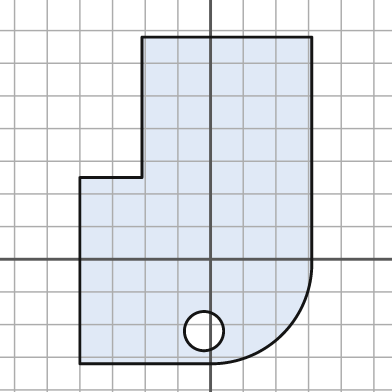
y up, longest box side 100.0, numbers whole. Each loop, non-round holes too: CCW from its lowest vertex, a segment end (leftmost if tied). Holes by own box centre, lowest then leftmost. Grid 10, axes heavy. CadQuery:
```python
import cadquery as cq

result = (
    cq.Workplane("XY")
    .moveTo(-40.0, -32.0)
    .lineTo(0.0, -32.0)
    .threePointArc((22.0, -23.0), (31.0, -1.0))
    .lineTo(31.0, 68.0)
    .lineTo(-21.0, 68.0)
    .lineTo(-21.0, 25.0)
    .lineTo(-40.0, 25.0)
    .close()
    .moveTo(-2.0, -22.0)
    .circle(6.0)
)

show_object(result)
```